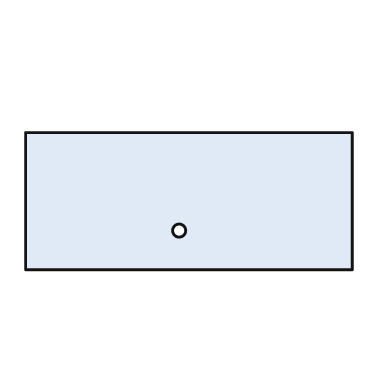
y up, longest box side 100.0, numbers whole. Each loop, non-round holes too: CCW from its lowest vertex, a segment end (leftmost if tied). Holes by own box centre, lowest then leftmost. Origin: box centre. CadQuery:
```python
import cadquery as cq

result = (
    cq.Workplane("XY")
    .moveTo(-50.0, -21.0)
    .lineTo(50.0, -21.0)
    .lineTo(50.0, 21.0)
    .lineTo(-50.0, 21.0)
    .close()
    .moveTo(-3.0, -9.0)
    .circle(2.0)
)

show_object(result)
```